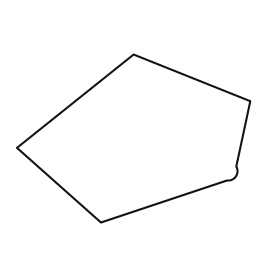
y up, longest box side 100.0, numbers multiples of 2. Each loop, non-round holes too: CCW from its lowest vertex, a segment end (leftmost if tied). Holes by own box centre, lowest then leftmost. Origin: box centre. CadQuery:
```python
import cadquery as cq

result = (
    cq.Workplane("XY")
    .moveTo(-14.0, -36.0)
    .lineTo(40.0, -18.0)
    .threePointArc((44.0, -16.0), (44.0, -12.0))
    .lineTo(50.0, 16.0)
    .lineTo(0.0, 36.0)
    .lineTo(-50.0, -4.0)
    .close()
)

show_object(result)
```